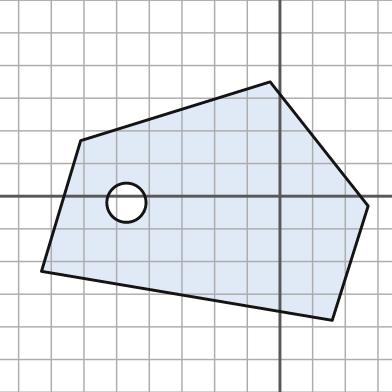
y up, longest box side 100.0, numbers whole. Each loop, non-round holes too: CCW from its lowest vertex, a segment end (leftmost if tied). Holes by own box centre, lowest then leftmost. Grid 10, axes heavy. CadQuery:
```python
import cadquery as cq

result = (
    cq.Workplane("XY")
    .moveTo(16.0, -38.0)
    .lineTo(27.0, -3.0)
    .lineTo(-3.0, 35.0)
    .lineTo(-61.0, 17.0)
    .lineTo(-73.0, -23.0)
    .close()
    .moveTo(-47.0, -2.0)
    .circle(6.0)
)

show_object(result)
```